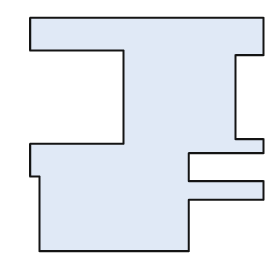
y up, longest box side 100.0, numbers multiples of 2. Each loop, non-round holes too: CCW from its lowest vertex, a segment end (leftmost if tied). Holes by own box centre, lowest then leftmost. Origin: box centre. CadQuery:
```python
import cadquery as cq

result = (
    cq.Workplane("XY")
    .moveTo(-46.0, -50.0)
    .lineTo(18.0, -50.0)
    .lineTo(18.0, -28.0)
    .lineTo(50.0, -28.0)
    .lineTo(50.0, -20.0)
    .lineTo(18.0, -20.0)
    .lineTo(18.0, -8.0)
    .lineTo(50.0, -8.0)
    .lineTo(50.0, -2.0)
    .lineTo(38.0, -2.0)
    .lineTo(38.0, 34.0)
    .lineTo(50.0, 34.0)
    .lineTo(50.0, 50.0)
    .lineTo(-50.0, 50.0)
    .lineTo(-50.0, 36.0)
    .lineTo(-10.0, 36.0)
    .lineTo(-10.0, -4.0)
    .lineTo(-50.0, -4.0)
    .lineTo(-50.0, -18.0)
    .lineTo(-46.0, -18.0)
    .close()
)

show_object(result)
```